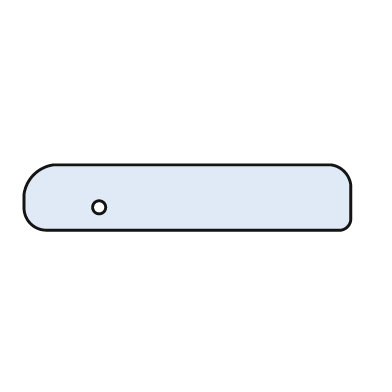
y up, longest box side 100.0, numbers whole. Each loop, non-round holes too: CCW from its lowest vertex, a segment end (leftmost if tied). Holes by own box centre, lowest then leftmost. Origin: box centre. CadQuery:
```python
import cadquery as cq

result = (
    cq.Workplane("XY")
    .moveTo(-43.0, -10.0)
    .lineTo(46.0, -10.0)
    .threePointArc((49.0, -9.0), (50.0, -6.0))
    .lineTo(50.0, 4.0)
    .threePointArc((48.0, 8.0), (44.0, 10.0))
    .lineTo(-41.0, 10.0)
    .threePointArc((-47.0, 7.0), (-50.0, 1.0))
    .lineTo(-50.0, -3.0)
    .threePointArc((-48.0, -8.0), (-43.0, -10.0))
    .close()
    .moveTo(-27.0, -3.0)
    .circle(2.0)
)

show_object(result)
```